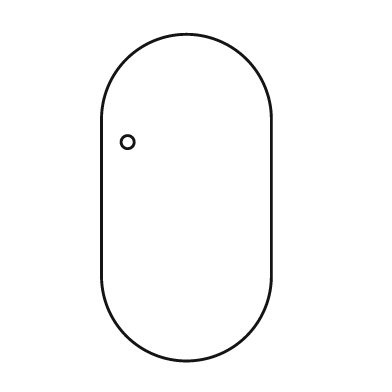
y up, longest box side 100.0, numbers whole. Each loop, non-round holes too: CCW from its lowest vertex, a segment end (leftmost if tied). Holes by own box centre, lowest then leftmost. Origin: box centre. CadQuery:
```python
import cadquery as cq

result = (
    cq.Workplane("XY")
    .moveTo(-26.0, -24.0)
    .threePointArc((0.0, -50.0), (26.0, -24.0))
    .lineTo(26.0, 24.0)
    .threePointArc((0.0, 50.0), (-26.0, 24.0))
    .close()
    .moveTo(-18.0, 17.0)
    .circle(2.0)
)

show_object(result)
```